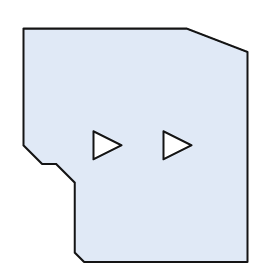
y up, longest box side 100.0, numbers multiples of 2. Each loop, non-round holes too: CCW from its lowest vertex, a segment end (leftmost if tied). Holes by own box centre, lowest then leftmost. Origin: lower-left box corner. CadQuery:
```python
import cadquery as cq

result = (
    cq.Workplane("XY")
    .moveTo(26.0, 0.0)
    .lineTo(96.0, 0.0)
    .lineTo(96.0, 90.0)
    .lineTo(70.0, 100.0)
    .lineTo(0.0, 100.0)
    .lineTo(0.0, 50.0)
    .lineTo(8.0, 42.0)
    .lineTo(14.0, 42.0)
    .lineTo(22.0, 34.0)
    .lineTo(22.0, 4.0)
    .close()
    .moveTo(30.0, 44.0)
    .lineTo(42.0, 50.0)
    .lineTo(30.0, 56.0)
    .close()
    .moveTo(60.0, 44.0)
    .lineTo(72.0, 50.0)
    .lineTo(60.0, 56.0)
    .close()
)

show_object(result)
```